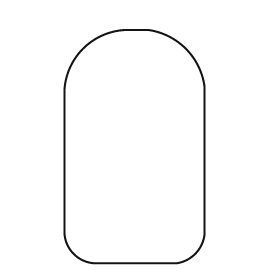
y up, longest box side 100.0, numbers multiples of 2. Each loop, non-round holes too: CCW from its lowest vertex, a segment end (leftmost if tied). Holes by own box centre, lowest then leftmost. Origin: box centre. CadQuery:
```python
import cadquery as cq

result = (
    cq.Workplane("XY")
    .moveTo(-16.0, -50.0)
    .lineTo(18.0, -50.0)
    .threePointArc((26.0, -46.0), (30.0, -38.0))
    .lineTo(30.0, 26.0)
    .threePointArc((22.0, 42.0), (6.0, 50.0))
    .lineTo(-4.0, 50.0)
    .threePointArc((-22.0, 42.0), (-30.0, 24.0))
    .lineTo(-30.0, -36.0)
    .threePointArc((-26.0, -46.0), (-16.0, -50.0))
    .close()
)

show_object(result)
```